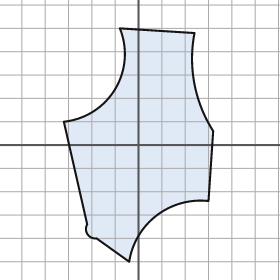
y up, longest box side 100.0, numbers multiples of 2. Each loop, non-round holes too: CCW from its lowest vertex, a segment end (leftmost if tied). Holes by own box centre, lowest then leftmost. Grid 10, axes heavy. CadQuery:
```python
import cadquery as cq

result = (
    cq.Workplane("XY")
    .moveTo(-4.0, -50.0)
    .threePointArc((8.0, -30.0), (30.0, -24.0))
    .lineTo(32.0, 6.0)
    .threePointArc((24.0, 26.0), (24.0, 48.0))
    .lineTo(-8.0, 50.0)
    .threePointArc((-10.0, 24.0), (-32.0, 10.0))
    .lineTo(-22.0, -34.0)
    .threePointArc((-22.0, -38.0), (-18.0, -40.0))
    .close()
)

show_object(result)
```